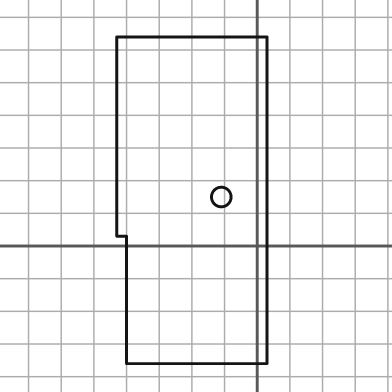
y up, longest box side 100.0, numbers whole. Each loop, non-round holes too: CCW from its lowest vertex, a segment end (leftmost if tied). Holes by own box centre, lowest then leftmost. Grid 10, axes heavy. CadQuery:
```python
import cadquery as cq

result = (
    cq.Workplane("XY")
    .moveTo(-40.0, -36.0)
    .lineTo(3.0, -36.0)
    .lineTo(3.0, 64.0)
    .lineTo(-43.0, 64.0)
    .lineTo(-43.0, 3.0)
    .lineTo(-40.0, 3.0)
    .close()
    .moveTo(-11.0, 15.0)
    .circle(3.0)
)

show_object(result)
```